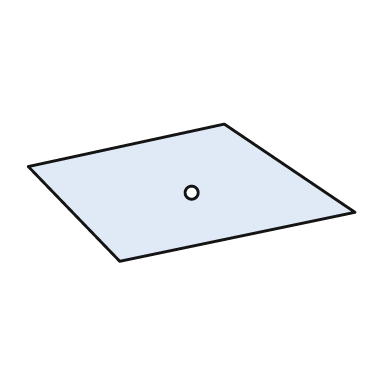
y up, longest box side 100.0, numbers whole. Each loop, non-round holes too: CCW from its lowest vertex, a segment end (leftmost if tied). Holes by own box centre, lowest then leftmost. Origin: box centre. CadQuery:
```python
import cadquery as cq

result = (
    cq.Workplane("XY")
    .moveTo(-22.0, -21.0)
    .lineTo(50.0, -6.0)
    .lineTo(10.0, 21.0)
    .lineTo(-50.0, 8.0)
    .close()
    .moveTo(0.0, 0.0)
    .circle(2.0)
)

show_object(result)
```